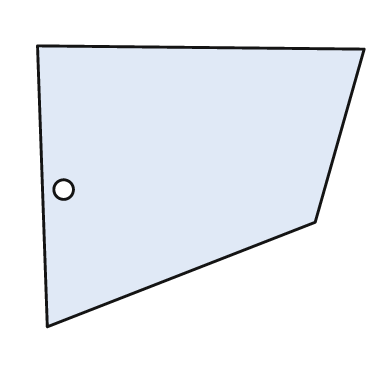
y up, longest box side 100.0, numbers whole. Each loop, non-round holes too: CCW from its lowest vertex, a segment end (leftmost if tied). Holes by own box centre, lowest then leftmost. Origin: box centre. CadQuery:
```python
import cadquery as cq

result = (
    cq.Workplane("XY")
    .moveTo(-47.0, -43.0)
    .lineTo(35.0, -11.0)
    .lineTo(50.0, 42.0)
    .lineTo(-50.0, 43.0)
    .close()
    .moveTo(-42.0, -1.0)
    .circle(3.0)
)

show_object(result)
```